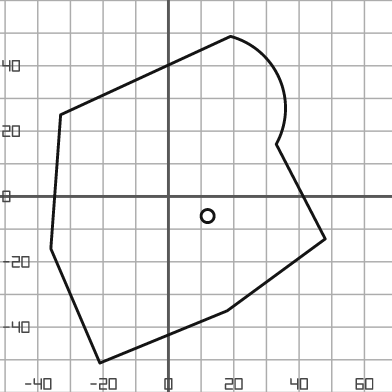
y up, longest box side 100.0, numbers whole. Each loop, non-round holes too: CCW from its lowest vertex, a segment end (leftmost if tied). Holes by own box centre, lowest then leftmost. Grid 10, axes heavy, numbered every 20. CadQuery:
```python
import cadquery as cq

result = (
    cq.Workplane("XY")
    .moveTo(-21.0, -51.0)
    .lineTo(18.0, -35.0)
    .lineTo(48.0, -13.0)
    .lineTo(33.0, 16.0)
    .threePointArc((34.0, 36.0), (19.0, 49.0))
    .lineTo(-33.0, 25.0)
    .lineTo(-36.0, -16.0)
    .close()
    .moveTo(12.0, -6.0)
    .circle(2.0)
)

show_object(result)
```